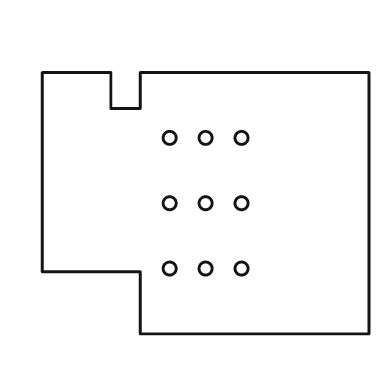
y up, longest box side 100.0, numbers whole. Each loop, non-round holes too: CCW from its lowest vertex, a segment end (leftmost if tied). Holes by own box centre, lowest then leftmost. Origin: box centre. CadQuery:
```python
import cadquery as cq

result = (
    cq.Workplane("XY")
    .moveTo(-20.0, -40.0)
    .lineTo(50.0, -40.0)
    .lineTo(50.0, 40.0)
    .lineTo(-20.0, 40.0)
    .lineTo(-20.0, 29.0)
    .lineTo(-29.0, 29.0)
    .lineTo(-29.0, 40.0)
    .lineTo(-50.0, 40.0)
    .lineTo(-50.0, -21.0)
    .lineTo(-20.0, -21.0)
    .close()
    .moveTo(-11.0, -20.0)
    .circle(2.0)
    .moveTo(0.0, -20.0)
    .circle(2.0)
    .moveTo(11.0, -20.0)
    .circle(2.0)
    .moveTo(-11.0, 0.0)
    .circle(2.0)
    .moveTo(0.0, 0.0)
    .circle(2.0)
    .moveTo(11.0, 0.0)
    .circle(2.0)
    .moveTo(-11.0, 20.0)
    .circle(2.0)
    .moveTo(0.0, 20.0)
    .circle(2.0)
    .moveTo(11.0, 20.0)
    .circle(2.0)
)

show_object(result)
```